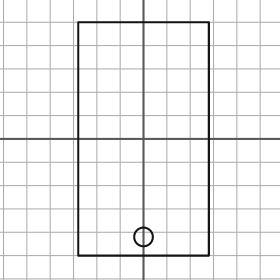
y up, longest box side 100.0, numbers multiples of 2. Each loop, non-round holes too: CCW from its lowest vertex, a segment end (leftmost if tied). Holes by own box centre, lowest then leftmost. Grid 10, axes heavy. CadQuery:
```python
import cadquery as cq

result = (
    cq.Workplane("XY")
    .moveTo(-28.0, -50.0)
    .lineTo(28.0, -50.0)
    .lineTo(28.0, 50.0)
    .lineTo(-28.0, 50.0)
    .close()
    .moveTo(0.0, -42.0)
    .circle(4.0)
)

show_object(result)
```